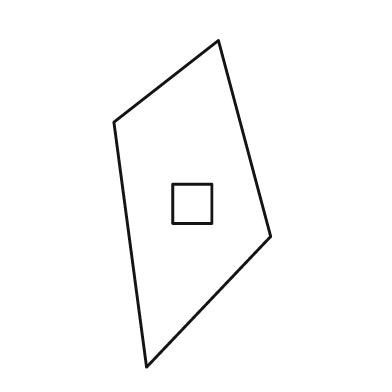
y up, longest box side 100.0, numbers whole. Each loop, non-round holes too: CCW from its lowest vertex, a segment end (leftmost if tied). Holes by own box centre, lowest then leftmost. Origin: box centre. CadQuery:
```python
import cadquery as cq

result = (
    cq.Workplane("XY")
    .moveTo(-14.0, -50.0)
    .lineTo(24.0, -10.0)
    .lineTo(8.0, 50.0)
    .lineTo(-24.0, 25.0)
    .close()
    .moveTo(-6.0, -6.0)
    .lineTo(6.0, -6.0)
    .lineTo(6.0, 6.0)
    .lineTo(-6.0, 6.0)
    .close()
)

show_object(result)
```